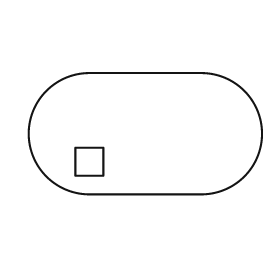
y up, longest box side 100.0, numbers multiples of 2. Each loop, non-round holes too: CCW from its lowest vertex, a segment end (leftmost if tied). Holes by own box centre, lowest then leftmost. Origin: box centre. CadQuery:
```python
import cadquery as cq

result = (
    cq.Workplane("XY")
    .moveTo(-24.0, -26.0)
    .lineTo(24.0, -26.0)
    .threePointArc((50.0, 0.0), (24.0, 26.0))
    .lineTo(-24.0, 26.0)
    .threePointArc((-50.0, 0.0), (-24.0, -26.0))
    .close()
    .moveTo(-30.0, -18.0)
    .lineTo(-18.0, -18.0)
    .lineTo(-18.0, -6.0)
    .lineTo(-30.0, -6.0)
    .close()
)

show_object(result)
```